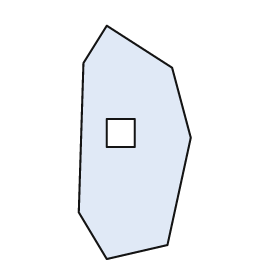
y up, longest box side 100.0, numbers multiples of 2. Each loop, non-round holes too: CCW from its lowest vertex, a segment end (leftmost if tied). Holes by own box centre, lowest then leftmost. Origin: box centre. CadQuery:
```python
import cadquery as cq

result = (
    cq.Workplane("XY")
    .moveTo(-12.0, -50.0)
    .lineTo(14.0, -44.0)
    .lineTo(24.0, 2.0)
    .lineTo(16.0, 32.0)
    .lineTo(-12.0, 50.0)
    .lineTo(-22.0, 34.0)
    .lineTo(-24.0, -30.0)
    .close()
    .moveTo(-12.0, -2.0)
    .lineTo(0.0, -2.0)
    .lineTo(0.0, 10.0)
    .lineTo(-12.0, 10.0)
    .close()
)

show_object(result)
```